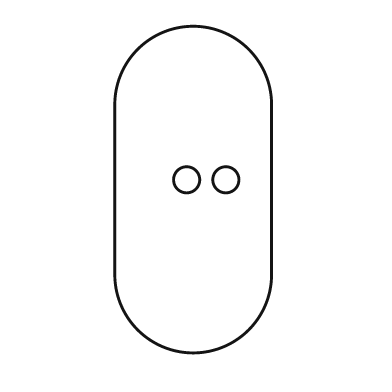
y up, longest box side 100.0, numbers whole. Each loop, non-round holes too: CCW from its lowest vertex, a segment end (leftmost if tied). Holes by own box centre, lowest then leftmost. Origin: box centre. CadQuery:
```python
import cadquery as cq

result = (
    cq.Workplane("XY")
    .moveTo(-24.0, -26.0)
    .threePointArc((0.0, -50.0), (24.0, -26.0))
    .lineTo(24.0, 26.0)
    .threePointArc((0.0, 50.0), (-24.0, 26.0))
    .close()
    .moveTo(-2.0, 3.0)
    .circle(4.0)
    .moveTo(10.0, 3.0)
    .circle(4.0)
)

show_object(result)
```